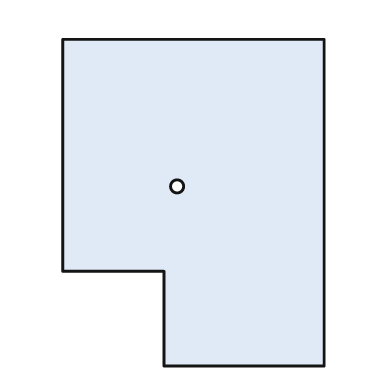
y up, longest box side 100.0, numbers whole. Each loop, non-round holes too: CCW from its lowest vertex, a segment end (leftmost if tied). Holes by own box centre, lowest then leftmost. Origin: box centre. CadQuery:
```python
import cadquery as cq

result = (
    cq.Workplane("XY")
    .moveTo(-9.0, -50.0)
    .lineTo(40.0, -50.0)
    .lineTo(40.0, 50.0)
    .lineTo(-40.0, 50.0)
    .lineTo(-40.0, -21.0)
    .lineTo(-9.0, -21.0)
    .close()
    .moveTo(-5.0, 5.0)
    .circle(2.0)
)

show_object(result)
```